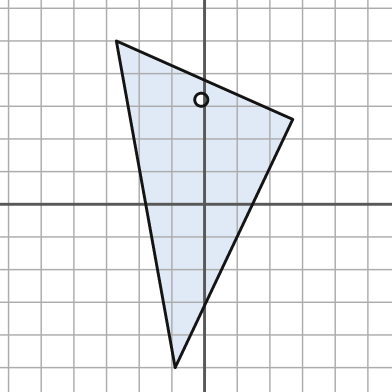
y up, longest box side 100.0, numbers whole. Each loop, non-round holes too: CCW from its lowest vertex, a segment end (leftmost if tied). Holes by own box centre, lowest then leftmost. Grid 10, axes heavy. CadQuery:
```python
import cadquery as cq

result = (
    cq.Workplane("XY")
    .moveTo(-9.0, -50.0)
    .lineTo(27.0, 26.0)
    .lineTo(-27.0, 50.0)
    .close()
    .moveTo(-1.0, 32.0)
    .circle(2.0)
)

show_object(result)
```